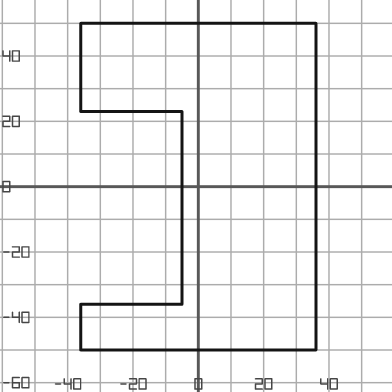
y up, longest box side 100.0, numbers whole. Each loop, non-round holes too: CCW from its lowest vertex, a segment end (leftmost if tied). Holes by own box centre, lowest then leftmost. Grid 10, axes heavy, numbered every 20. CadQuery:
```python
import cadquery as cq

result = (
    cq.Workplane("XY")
    .moveTo(-36.0, -50.0)
    .lineTo(36.0, -50.0)
    .lineTo(36.0, 50.0)
    .lineTo(-36.0, 50.0)
    .lineTo(-36.0, 23.0)
    .lineTo(-5.0, 23.0)
    .lineTo(-5.0, -36.0)
    .lineTo(-36.0, -36.0)
    .close()
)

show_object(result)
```